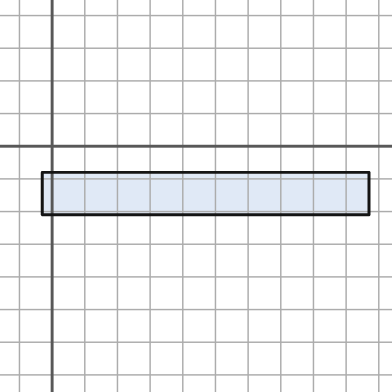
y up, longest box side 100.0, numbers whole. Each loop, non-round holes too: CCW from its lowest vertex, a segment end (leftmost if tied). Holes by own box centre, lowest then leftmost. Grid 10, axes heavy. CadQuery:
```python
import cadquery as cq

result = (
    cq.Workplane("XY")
    .moveTo(-3.0, -21.0)
    .lineTo(97.0, -21.0)
    .lineTo(97.0, -8.0)
    .lineTo(-3.0, -8.0)
    .close()
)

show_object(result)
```